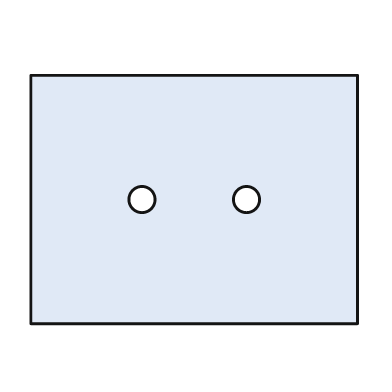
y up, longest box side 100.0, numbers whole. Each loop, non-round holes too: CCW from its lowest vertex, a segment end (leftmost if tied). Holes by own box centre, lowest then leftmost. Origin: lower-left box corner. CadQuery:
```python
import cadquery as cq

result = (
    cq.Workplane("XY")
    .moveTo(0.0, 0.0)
    .lineTo(100.0, 0.0)
    .lineTo(100.0, 76.0)
    .lineTo(0.0, 76.0)
    .close()
    .moveTo(34.0, 38.0)
    .circle(4.0)
    .moveTo(66.0, 38.0)
    .circle(4.0)
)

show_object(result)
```